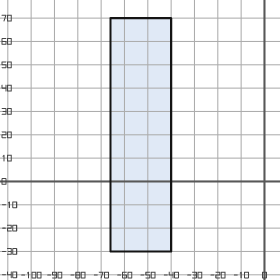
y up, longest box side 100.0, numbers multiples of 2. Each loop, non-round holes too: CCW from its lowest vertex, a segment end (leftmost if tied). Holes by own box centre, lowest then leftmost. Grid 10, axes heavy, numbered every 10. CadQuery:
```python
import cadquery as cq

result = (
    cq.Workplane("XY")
    .moveTo(-66.0, -30.0)
    .lineTo(-40.0, -30.0)
    .lineTo(-40.0, 70.0)
    .lineTo(-66.0, 70.0)
    .close()
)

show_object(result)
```